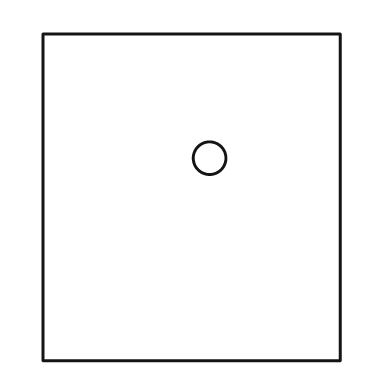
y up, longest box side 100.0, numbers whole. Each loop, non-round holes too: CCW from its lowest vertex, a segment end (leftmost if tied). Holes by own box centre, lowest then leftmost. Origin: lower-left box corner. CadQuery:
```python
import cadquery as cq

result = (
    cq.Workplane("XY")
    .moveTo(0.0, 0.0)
    .lineTo(91.0, 0.0)
    .lineTo(91.0, 100.0)
    .lineTo(0.0, 100.0)
    .close()
    .moveTo(51.0, 62.0)
    .circle(5.0)
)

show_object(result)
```